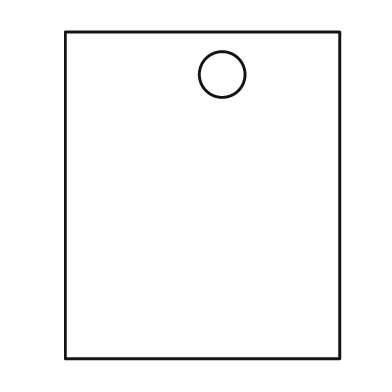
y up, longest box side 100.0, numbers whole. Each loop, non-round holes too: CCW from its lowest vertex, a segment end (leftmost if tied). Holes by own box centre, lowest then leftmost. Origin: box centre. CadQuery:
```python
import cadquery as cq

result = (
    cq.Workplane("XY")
    .moveTo(-42.0, -50.0)
    .lineTo(42.0, -50.0)
    .lineTo(42.0, 50.0)
    .lineTo(-42.0, 50.0)
    .close()
    .moveTo(6.0, 37.0)
    .circle(7.0)
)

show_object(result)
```